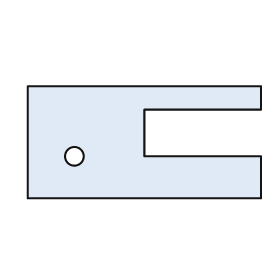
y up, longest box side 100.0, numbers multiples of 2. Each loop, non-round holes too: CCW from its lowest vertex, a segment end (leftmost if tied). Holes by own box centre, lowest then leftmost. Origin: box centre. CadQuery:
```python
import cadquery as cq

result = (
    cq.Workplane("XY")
    .moveTo(-50.0, -24.0)
    .lineTo(50.0, -24.0)
    .lineTo(50.0, -6.0)
    .lineTo(0.0, -6.0)
    .lineTo(0.0, 14.0)
    .lineTo(50.0, 14.0)
    .lineTo(50.0, 24.0)
    .lineTo(-50.0, 24.0)
    .close()
    .moveTo(-30.0, -6.0)
    .circle(4.0)
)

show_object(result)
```